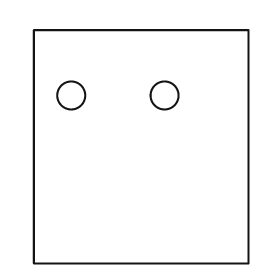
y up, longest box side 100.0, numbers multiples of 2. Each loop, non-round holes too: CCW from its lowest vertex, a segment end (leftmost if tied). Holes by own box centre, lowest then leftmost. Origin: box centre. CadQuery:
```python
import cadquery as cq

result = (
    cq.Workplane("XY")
    .moveTo(-46.0, -50.0)
    .lineTo(46.0, -50.0)
    .lineTo(46.0, 50.0)
    .lineTo(-46.0, 50.0)
    .close()
    .moveTo(-30.0, 22.0)
    .circle(6.0)
    .moveTo(10.0, 22.0)
    .circle(6.0)
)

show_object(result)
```